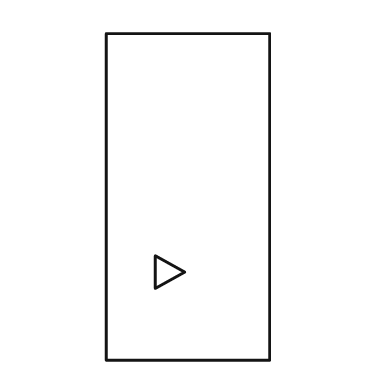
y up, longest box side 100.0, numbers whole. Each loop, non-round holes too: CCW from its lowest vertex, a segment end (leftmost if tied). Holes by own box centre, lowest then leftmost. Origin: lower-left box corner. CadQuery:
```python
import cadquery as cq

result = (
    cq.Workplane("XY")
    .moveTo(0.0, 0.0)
    .lineTo(50.0, 0.0)
    .lineTo(50.0, 100.0)
    .lineTo(0.0, 100.0)
    .close()
    .moveTo(15.0, 22.0)
    .lineTo(24.0, 27.0)
    .lineTo(15.0, 32.0)
    .close()
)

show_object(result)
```